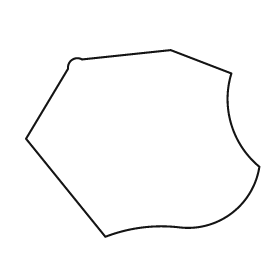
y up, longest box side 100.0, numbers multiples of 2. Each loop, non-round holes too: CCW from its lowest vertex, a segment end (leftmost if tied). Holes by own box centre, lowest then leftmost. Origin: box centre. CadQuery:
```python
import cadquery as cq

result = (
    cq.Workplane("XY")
    .moveTo(-16.0, -40.0)
    .threePointArc((0.0, -36.0), (16.0, -36.0))
    .threePointArc((38.0, -30.0), (50.0, -10.0))
    .threePointArc((38.0, 8.0), (38.0, 30.0))
    .lineTo(12.0, 40.0)
    .lineTo(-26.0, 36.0)
    .threePointArc((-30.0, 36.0), (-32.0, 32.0))
    .lineTo(-50.0, 2.0)
    .close()
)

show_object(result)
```